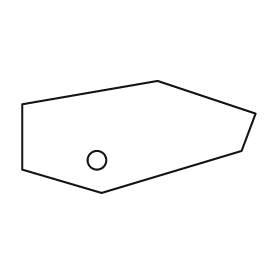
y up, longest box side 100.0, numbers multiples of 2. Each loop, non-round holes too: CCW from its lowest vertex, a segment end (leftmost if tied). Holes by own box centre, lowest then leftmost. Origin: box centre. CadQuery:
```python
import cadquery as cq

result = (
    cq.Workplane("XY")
    .moveTo(-16.0, -24.0)
    .lineTo(44.0, -6.0)
    .lineTo(50.0, 10.0)
    .lineTo(8.0, 24.0)
    .lineTo(-50.0, 14.0)
    .lineTo(-50.0, -14.0)
    .close()
    .moveTo(-18.0, -10.0)
    .circle(4.0)
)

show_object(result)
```